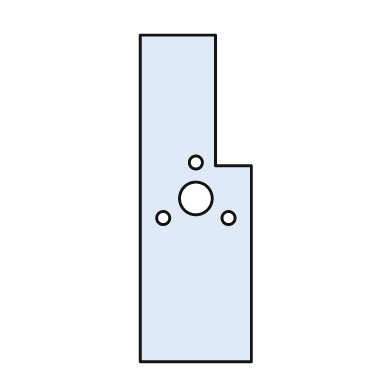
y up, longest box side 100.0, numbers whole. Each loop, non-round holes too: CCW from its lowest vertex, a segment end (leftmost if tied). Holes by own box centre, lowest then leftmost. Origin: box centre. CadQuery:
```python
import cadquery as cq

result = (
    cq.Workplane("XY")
    .moveTo(-17.0, -50.0)
    .lineTo(17.0, -50.0)
    .lineTo(17.0, 10.0)
    .lineTo(6.0, 10.0)
    .lineTo(6.0, 50.0)
    .lineTo(-17.0, 50.0)
    .close()
    .moveTo(-10.0, -6.0)
    .circle(2.0)
    .moveTo(10.0, -6.0)
    .circle(2.0)
    .moveTo(0.0, 0.0)
    .circle(5.0)
    .moveTo(0.0, 11.0)
    .circle(2.0)
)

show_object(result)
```